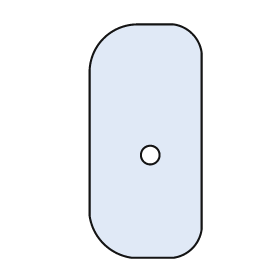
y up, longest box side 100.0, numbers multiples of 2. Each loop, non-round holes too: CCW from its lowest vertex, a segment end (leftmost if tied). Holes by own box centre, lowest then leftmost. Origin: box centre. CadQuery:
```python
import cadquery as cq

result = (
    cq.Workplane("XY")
    .moveTo(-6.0, -50.0)
    .lineTo(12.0, -50.0)
    .threePointArc((20.0, -46.0), (24.0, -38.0))
    .lineTo(24.0, 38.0)
    .threePointArc((20.0, 46.0), (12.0, 50.0))
    .lineTo(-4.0, 50.0)
    .threePointArc((-18.0, 44.0), (-24.0, 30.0))
    .lineTo(-24.0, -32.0)
    .threePointArc((-18.0, -44.0), (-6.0, -50.0))
    .close()
    .moveTo(2.0, -6.0)
    .circle(4.0)
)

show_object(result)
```